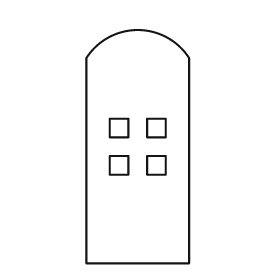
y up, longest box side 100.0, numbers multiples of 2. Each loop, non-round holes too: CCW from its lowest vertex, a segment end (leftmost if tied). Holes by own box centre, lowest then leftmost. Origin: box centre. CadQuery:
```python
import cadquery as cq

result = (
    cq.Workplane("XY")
    .moveTo(-22.0, -50.0)
    .lineTo(22.0, -50.0)
    .lineTo(22.0, 38.0)
    .threePointArc((0.0, 50.0), (-22.0, 38.0))
    .close()
    .moveTo(-12.0, -12.0)
    .lineTo(-4.0, -12.0)
    .lineTo(-4.0, -4.0)
    .lineTo(-12.0, -4.0)
    .close()
    .moveTo(4.0, -12.0)
    .lineTo(12.0, -12.0)
    .lineTo(12.0, -4.0)
    .lineTo(4.0, -4.0)
    .close()
    .moveTo(-12.0, 4.0)
    .lineTo(-4.0, 4.0)
    .lineTo(-4.0, 12.0)
    .lineTo(-12.0, 12.0)
    .close()
    .moveTo(4.0, 4.0)
    .lineTo(12.0, 4.0)
    .lineTo(12.0, 12.0)
    .lineTo(4.0, 12.0)
    .close()
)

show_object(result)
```